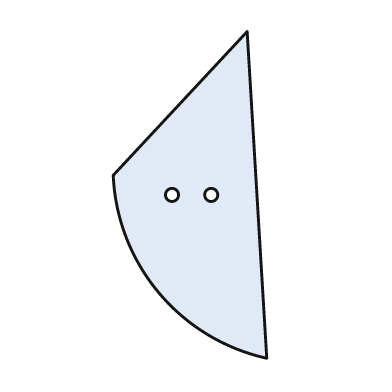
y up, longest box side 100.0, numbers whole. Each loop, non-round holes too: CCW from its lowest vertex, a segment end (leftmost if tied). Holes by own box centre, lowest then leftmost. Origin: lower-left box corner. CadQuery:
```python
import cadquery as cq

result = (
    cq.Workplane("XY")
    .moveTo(47.0, 0.0)
    .lineTo(41.0, 100.0)
    .lineTo(0.0, 56.0)
    .threePointArc((14.0, 20.0), (47.0, 0.0))
    .close()
    .moveTo(18.0, 50.0)
    .circle(2.0)
    .moveTo(30.0, 50.0)
    .circle(2.0)
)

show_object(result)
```